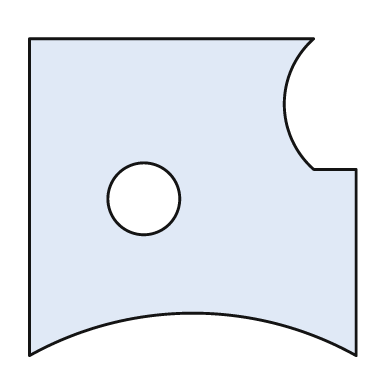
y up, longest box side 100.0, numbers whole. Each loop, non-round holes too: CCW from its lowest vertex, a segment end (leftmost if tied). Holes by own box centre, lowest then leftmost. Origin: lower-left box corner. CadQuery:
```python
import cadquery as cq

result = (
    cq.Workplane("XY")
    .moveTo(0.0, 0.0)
    .threePointArc((50.0, 13.0), (100.0, 0.0))
    .lineTo(100.0, 57.0)
    .lineTo(87.0, 57.0)
    .threePointArc((78.0, 77.0), (87.0, 97.0))
    .lineTo(0.0, 97.0)
    .close()
    .moveTo(35.0, 48.0)
    .circle(11.0)
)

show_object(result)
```